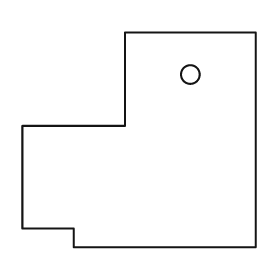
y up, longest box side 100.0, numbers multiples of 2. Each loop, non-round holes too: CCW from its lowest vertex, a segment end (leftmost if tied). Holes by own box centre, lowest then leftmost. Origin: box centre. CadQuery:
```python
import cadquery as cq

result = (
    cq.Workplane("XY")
    .moveTo(-28.0, -46.0)
    .lineTo(50.0, -46.0)
    .lineTo(50.0, 46.0)
    .lineTo(-6.0, 46.0)
    .lineTo(-6.0, 6.0)
    .lineTo(-50.0, 6.0)
    .lineTo(-50.0, -38.0)
    .lineTo(-28.0, -38.0)
    .close()
    .moveTo(22.0, 28.0)
    .circle(4.0)
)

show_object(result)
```